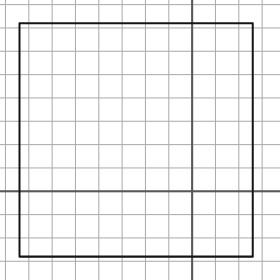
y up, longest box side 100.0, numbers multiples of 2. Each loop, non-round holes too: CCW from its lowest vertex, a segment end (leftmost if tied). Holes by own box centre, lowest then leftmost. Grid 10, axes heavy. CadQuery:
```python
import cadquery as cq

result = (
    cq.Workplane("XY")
    .moveTo(-74.0, -28.0)
    .lineTo(26.0, -28.0)
    .lineTo(26.0, 72.0)
    .lineTo(-74.0, 72.0)
    .close()
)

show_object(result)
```